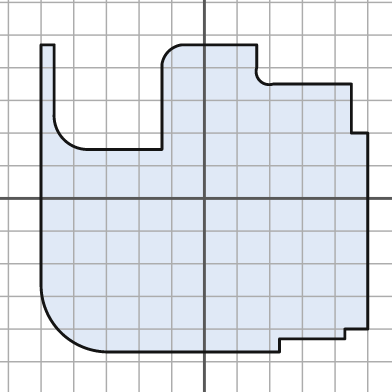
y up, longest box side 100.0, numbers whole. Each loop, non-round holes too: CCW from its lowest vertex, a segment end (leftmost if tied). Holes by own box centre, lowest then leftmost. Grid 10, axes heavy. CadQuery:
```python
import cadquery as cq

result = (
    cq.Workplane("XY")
    .moveTo(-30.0, -47.0)
    .lineTo(23.0, -47.0)
    .lineTo(23.0, -43.0)
    .lineTo(43.0, -43.0)
    .lineTo(43.0, -40.0)
    .lineTo(50.0, -40.0)
    .lineTo(50.0, 20.0)
    .lineTo(45.0, 20.0)
    .lineTo(45.0, 35.0)
    .lineTo(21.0, 35.0)
    .threePointArc((17.0, 36.0), (16.0, 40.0))
    .lineTo(16.0, 47.0)
    .lineTo(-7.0, 47.0)
    .threePointArc((-11.0, 45.0), (-13.0, 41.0))
    .lineTo(-13.0, 15.0)
    .lineTo(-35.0, 15.0)
    .threePointArc((-43.0, 18.0), (-46.0, 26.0))
    .lineTo(-46.0, 47.0)
    .lineTo(-50.0, 47.0)
    .lineTo(-50.0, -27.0)
    .threePointArc((-44.0, -41.0), (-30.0, -47.0))
    .close()
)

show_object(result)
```